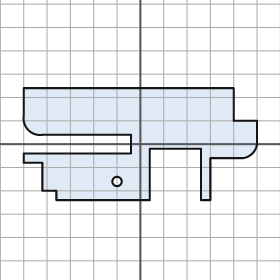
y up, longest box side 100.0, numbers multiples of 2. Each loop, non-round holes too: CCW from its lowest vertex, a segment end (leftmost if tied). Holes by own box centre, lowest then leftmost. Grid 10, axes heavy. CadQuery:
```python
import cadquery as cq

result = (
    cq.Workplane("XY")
    .moveTo(-36.0, -24.0)
    .lineTo(4.0, -24.0)
    .lineTo(4.0, -2.0)
    .lineTo(26.0, -2.0)
    .lineTo(26.0, -24.0)
    .lineTo(30.0, -24.0)
    .lineTo(30.0, -6.0)
    .lineTo(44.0, -6.0)
    .threePointArc((48.0, -4.0), (50.0, 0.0))
    .lineTo(50.0, 10.0)
    .lineTo(40.0, 10.0)
    .lineTo(40.0, 24.0)
    .lineTo(-50.0, 24.0)
    .lineTo(-50.0, 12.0)
    .threePointArc((-48.0, 6.0), (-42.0, 4.0))
    .lineTo(-4.0, 4.0)
    .lineTo(-4.0, -4.0)
    .lineTo(-50.0, -4.0)
    .lineTo(-50.0, -8.0)
    .lineTo(-42.0, -8.0)
    .lineTo(-42.0, -20.0)
    .lineTo(-36.0, -20.0)
    .close()
    .moveTo(-10.0, -16.0)
    .circle(2.0)
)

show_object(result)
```